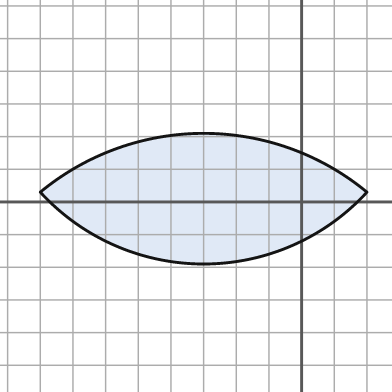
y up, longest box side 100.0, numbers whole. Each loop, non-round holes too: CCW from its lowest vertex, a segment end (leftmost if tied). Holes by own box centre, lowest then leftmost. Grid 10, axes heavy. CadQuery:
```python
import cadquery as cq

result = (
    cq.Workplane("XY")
    .moveTo(-80.0, 3.0)
    .threePointArc((-30.0, -19.0), (20.0, 3.0))
    .threePointArc((-30.0, 21.0), (-80.0, 3.0))
    .close()
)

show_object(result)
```